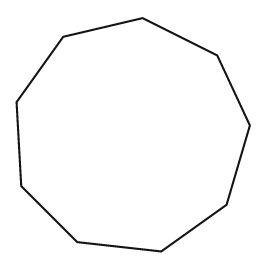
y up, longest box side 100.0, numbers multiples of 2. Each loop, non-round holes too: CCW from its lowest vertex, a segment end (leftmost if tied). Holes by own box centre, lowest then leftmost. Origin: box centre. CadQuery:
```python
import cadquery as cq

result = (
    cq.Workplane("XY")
    .moveTo(12.0, -50.0)
    .lineTo(40.0, -30.0)
    .lineTo(50.0, 4.0)
    .lineTo(36.0, 34.0)
    .lineTo(4.0, 50.0)
    .lineTo(-30.0, 42.0)
    .lineTo(-50.0, 14.0)
    .lineTo(-48.0, -22.0)
    .lineTo(-24.0, -46.0)
    .close()
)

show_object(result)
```